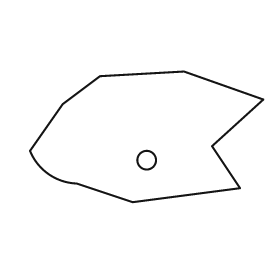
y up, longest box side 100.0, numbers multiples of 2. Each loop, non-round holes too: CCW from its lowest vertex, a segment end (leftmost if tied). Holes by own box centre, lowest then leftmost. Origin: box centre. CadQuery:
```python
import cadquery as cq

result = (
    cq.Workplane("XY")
    .moveTo(-6.0, -28.0)
    .lineTo(40.0, -22.0)
    .lineTo(28.0, -4.0)
    .lineTo(50.0, 16.0)
    .lineTo(16.0, 28.0)
    .lineTo(-20.0, 26.0)
    .lineTo(-36.0, 14.0)
    .lineTo(-50.0, -6.0)
    .threePointArc((-42.0, -16.0), (-30.0, -20.0))
    .close()
    .moveTo(0.0, -10.0)
    .circle(4.0)
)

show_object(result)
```